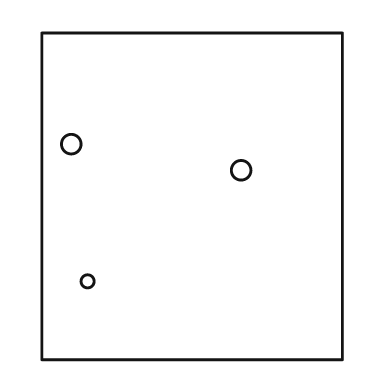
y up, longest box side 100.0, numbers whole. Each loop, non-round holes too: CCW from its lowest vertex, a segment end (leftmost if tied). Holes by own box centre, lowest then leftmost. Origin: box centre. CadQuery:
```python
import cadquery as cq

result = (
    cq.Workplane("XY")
    .moveTo(-46.0, -50.0)
    .lineTo(46.0, -50.0)
    .lineTo(46.0, 50.0)
    .lineTo(-46.0, 50.0)
    .close()
    .moveTo(-32.0, -26.0)
    .circle(2.0)
    .moveTo(15.0, 8.0)
    .circle(3.0)
    .moveTo(-37.0, 16.0)
    .circle(3.0)
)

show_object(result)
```